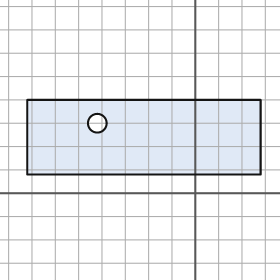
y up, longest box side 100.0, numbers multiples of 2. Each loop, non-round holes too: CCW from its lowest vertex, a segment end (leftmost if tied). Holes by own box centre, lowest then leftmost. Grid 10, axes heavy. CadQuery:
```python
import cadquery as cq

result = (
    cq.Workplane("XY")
    .moveTo(-72.0, 8.0)
    .lineTo(28.0, 8.0)
    .lineTo(28.0, 40.0)
    .lineTo(-72.0, 40.0)
    .close()
    .moveTo(-42.0, 30.0)
    .circle(4.0)
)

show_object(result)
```